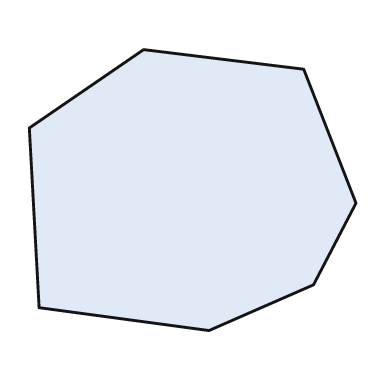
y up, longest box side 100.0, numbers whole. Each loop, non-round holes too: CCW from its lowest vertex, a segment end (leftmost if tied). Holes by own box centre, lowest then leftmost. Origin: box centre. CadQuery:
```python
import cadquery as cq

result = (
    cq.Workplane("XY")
    .moveTo(5.0, -43.0)
    .lineTo(37.0, -29.0)
    .lineTo(50.0, -4.0)
    .lineTo(34.0, 37.0)
    .lineTo(-15.0, 43.0)
    .lineTo(-50.0, 19.0)
    .lineTo(-47.0, -36.0)
    .close()
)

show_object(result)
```